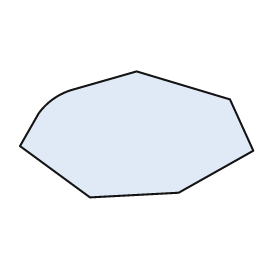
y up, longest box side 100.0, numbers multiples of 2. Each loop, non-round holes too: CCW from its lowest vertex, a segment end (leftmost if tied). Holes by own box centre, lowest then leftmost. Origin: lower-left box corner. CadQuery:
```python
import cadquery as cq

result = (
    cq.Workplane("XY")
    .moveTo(30.0, 0.0)
    .lineTo(68.0, 2.0)
    .lineTo(100.0, 20.0)
    .lineTo(90.0, 42.0)
    .lineTo(50.0, 54.0)
    .lineTo(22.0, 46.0)
    .threePointArc((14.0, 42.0), (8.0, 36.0))
    .lineTo(0.0, 22.0)
    .close()
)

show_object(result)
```